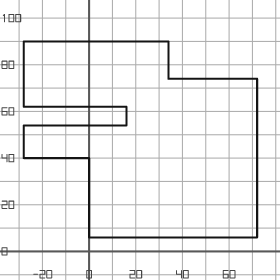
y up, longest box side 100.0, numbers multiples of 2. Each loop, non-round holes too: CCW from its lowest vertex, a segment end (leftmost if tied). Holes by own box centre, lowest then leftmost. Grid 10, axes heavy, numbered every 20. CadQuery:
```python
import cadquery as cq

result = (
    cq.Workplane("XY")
    .moveTo(0.0, 6.0)
    .lineTo(72.0, 6.0)
    .lineTo(72.0, 74.0)
    .lineTo(34.0, 74.0)
    .lineTo(34.0, 90.0)
    .lineTo(-28.0, 90.0)
    .lineTo(-28.0, 62.0)
    .lineTo(16.0, 62.0)
    .lineTo(16.0, 54.0)
    .lineTo(-28.0, 54.0)
    .lineTo(-28.0, 40.0)
    .lineTo(0.0, 40.0)
    .close()
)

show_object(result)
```